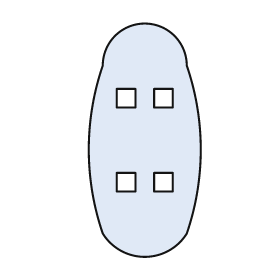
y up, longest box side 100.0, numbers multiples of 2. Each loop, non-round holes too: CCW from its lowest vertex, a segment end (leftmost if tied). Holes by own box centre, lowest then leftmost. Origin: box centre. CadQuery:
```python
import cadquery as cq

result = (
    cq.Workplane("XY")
    .moveTo(-18.0, -40.0)
    .threePointArc((0.0, -50.0), (18.0, -40.0))
    .threePointArc((24.0, -4.0), (18.0, 32.0))
    .threePointArc((0.0, 50.0), (-18.0, 32.0))
    .threePointArc((-24.0, -4.0), (-18.0, -40.0))
    .close()
    .moveTo(-12.0, -22.0)
    .lineTo(-4.0, -22.0)
    .lineTo(-4.0, -14.0)
    .lineTo(-12.0, -14.0)
    .close()
    .moveTo(4.0, -22.0)
    .lineTo(12.0, -22.0)
    .lineTo(12.0, -14.0)
    .lineTo(4.0, -14.0)
    .close()
    .moveTo(-12.0, 14.0)
    .lineTo(-4.0, 14.0)
    .lineTo(-4.0, 22.0)
    .lineTo(-12.0, 22.0)
    .close()
    .moveTo(4.0, 14.0)
    .lineTo(12.0, 14.0)
    .lineTo(12.0, 22.0)
    .lineTo(4.0, 22.0)
    .close()
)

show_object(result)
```